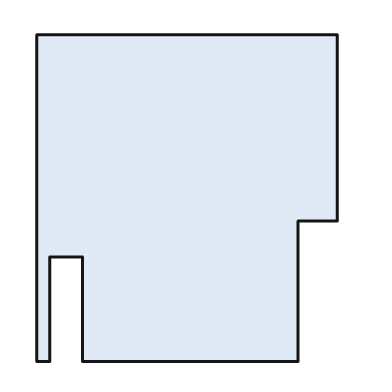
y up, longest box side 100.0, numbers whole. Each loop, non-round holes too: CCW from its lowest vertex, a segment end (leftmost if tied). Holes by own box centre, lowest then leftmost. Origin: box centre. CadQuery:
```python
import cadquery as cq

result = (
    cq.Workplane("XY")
    .moveTo(-46.0, -50.0)
    .lineTo(-42.0, -50.0)
    .lineTo(-42.0, -18.0)
    .lineTo(-32.0, -18.0)
    .lineTo(-32.0, -50.0)
    .lineTo(34.0, -50.0)
    .lineTo(34.0, -7.0)
    .lineTo(46.0, -7.0)
    .lineTo(46.0, 50.0)
    .lineTo(-46.0, 50.0)
    .close()
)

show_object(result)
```